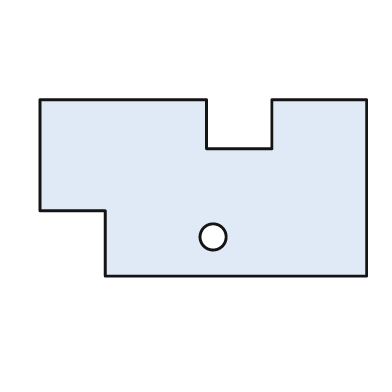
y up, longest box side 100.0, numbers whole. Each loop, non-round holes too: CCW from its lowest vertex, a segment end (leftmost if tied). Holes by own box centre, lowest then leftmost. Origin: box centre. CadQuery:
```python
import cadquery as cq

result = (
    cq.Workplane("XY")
    .moveTo(-30.0, -27.0)
    .lineTo(50.0, -27.0)
    .lineTo(50.0, 27.0)
    .lineTo(21.0, 27.0)
    .lineTo(21.0, 12.0)
    .lineTo(1.0, 12.0)
    .lineTo(1.0, 27.0)
    .lineTo(-50.0, 27.0)
    .lineTo(-50.0, -7.0)
    .lineTo(-30.0, -7.0)
    .close()
    .moveTo(3.0, -15.0)
    .circle(4.0)
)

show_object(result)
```